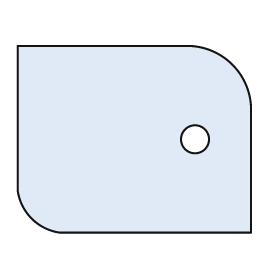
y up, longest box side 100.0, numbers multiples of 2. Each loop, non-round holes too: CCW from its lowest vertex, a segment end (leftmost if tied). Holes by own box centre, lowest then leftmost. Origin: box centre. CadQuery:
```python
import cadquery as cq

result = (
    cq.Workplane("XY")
    .moveTo(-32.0, -40.0)
    .lineTo(50.0, -40.0)
    .lineTo(50.0, 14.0)
    .threePointArc((42.0, 32.0), (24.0, 40.0))
    .lineTo(-50.0, 40.0)
    .lineTo(-50.0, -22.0)
    .threePointArc((-44.0, -34.0), (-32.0, -40.0))
    .close()
    .moveTo(26.0, 0.0)
    .circle(6.0)
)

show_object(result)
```